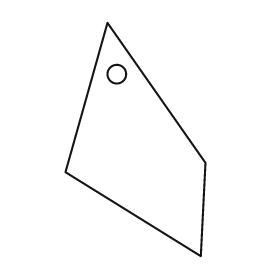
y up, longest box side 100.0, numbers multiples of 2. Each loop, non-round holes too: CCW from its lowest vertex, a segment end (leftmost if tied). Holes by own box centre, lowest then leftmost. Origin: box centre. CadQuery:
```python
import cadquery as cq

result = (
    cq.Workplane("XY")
    .moveTo(28.0, -50.0)
    .lineTo(30.0, -10.0)
    .lineTo(-12.0, 50.0)
    .lineTo(-30.0, -14.0)
    .close()
    .moveTo(-8.0, 28.0)
    .circle(4.0)
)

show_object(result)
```